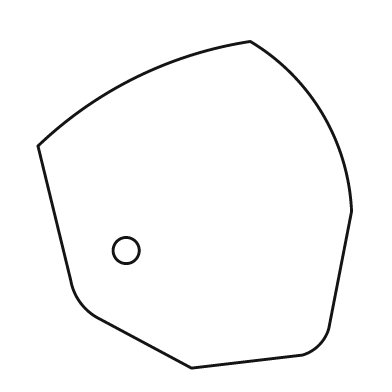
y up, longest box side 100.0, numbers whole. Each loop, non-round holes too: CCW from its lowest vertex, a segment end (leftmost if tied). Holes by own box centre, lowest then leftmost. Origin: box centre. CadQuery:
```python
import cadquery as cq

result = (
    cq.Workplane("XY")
    .moveTo(-1.0, -50.0)
    .lineTo(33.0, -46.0)
    .threePointArc((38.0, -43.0), (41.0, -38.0))
    .lineTo(48.0, -2.0)
    .threePointArc((39.0, 28.0), (17.0, 50.0))
    .threePointArc((-18.0, 39.0), (-48.0, 18.0))
    .lineTo(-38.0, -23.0)
    .threePointArc((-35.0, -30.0), (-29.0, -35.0))
    .close()
    .moveTo(-21.0, -14.0)
    .circle(4.0)
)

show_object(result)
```